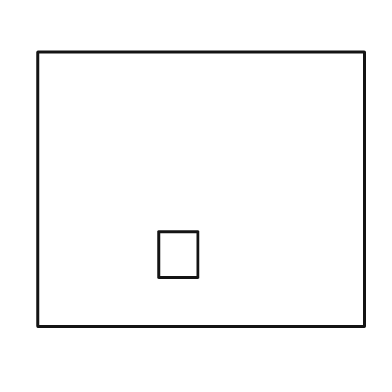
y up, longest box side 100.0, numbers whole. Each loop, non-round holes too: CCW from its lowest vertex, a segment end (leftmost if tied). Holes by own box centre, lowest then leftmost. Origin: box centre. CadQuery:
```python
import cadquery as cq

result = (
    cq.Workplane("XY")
    .moveTo(-50.0, -42.0)
    .lineTo(50.0, -42.0)
    .lineTo(50.0, 42.0)
    .lineTo(-50.0, 42.0)
    .close()
    .moveTo(-13.0, -27.0)
    .lineTo(-1.0, -27.0)
    .lineTo(-1.0, -13.0)
    .lineTo(-13.0, -13.0)
    .close()
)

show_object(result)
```